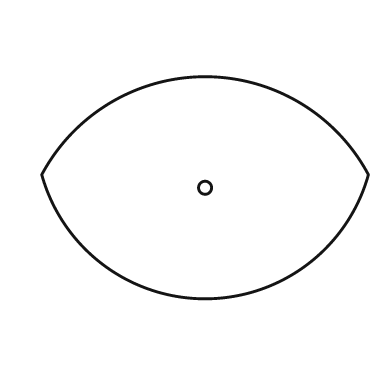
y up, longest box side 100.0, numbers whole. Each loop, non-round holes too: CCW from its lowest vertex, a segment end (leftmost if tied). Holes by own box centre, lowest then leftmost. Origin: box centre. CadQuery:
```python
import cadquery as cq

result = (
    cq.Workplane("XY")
    .moveTo(-50.0, 4.0)
    .threePointArc((0.0, -34.0), (50.0, 4.0))
    .threePointArc((0.0, 34.0), (-50.0, 4.0))
    .close()
    .moveTo(0.0, 0.0)
    .circle(2.0)
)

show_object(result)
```